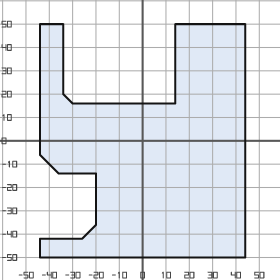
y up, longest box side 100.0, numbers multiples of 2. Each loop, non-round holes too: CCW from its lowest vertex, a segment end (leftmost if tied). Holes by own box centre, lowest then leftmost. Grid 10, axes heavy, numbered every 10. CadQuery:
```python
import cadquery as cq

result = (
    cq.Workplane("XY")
    .moveTo(-44.0, -50.0)
    .lineTo(44.0, -50.0)
    .lineTo(44.0, 50.0)
    .lineTo(14.0, 50.0)
    .lineTo(14.0, 16.0)
    .lineTo(-30.0, 16.0)
    .lineTo(-34.0, 20.0)
    .lineTo(-34.0, 50.0)
    .lineTo(-44.0, 50.0)
    .lineTo(-44.0, -6.0)
    .lineTo(-36.0, -14.0)
    .lineTo(-20.0, -14.0)
    .lineTo(-20.0, -36.0)
    .lineTo(-26.0, -42.0)
    .lineTo(-44.0, -42.0)
    .close()
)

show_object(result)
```